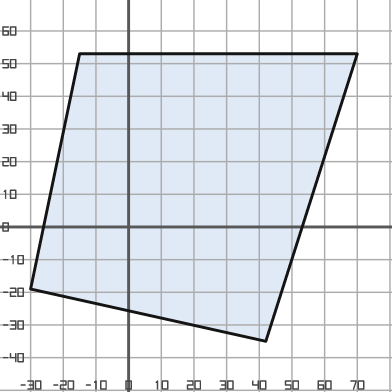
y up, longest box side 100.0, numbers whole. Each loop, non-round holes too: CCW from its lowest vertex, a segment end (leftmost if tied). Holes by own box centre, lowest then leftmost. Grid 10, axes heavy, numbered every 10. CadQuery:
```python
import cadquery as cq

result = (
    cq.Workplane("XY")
    .moveTo(42.0, -35.0)
    .lineTo(70.0, 53.0)
    .lineTo(-15.0, 53.0)
    .lineTo(-30.0, -19.0)
    .close()
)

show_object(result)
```